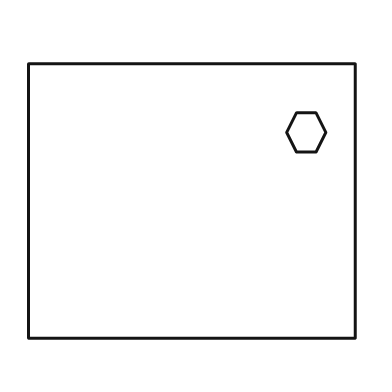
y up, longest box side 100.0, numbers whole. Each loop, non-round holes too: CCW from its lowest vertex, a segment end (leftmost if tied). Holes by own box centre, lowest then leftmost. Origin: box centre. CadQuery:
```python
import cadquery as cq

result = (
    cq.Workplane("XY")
    .moveTo(-50.0, -42.0)
    .lineTo(50.0, -42.0)
    .lineTo(50.0, 42.0)
    .lineTo(-50.0, 42.0)
    .close()
    .moveTo(32.0, 15.0)
    .lineTo(38.0, 15.0)
    .lineTo(41.0, 21.0)
    .lineTo(38.0, 27.0)
    .lineTo(32.0, 27.0)
    .lineTo(29.0, 21.0)
    .close()
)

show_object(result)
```